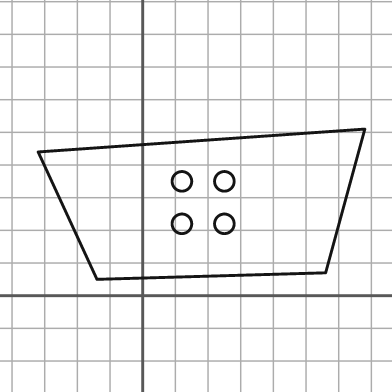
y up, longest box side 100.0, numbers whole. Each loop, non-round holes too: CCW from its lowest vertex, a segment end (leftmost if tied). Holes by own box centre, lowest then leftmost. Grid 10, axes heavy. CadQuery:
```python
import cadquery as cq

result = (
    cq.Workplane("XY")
    .moveTo(-14.0, 5.0)
    .lineTo(56.0, 7.0)
    .lineTo(68.0, 51.0)
    .lineTo(-32.0, 44.0)
    .close()
    .moveTo(12.0, 22.0)
    .circle(3.0)
    .moveTo(25.0, 22.0)
    .circle(3.0)
    .moveTo(12.0, 35.0)
    .circle(3.0)
    .moveTo(25.0, 35.0)
    .circle(3.0)
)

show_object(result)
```